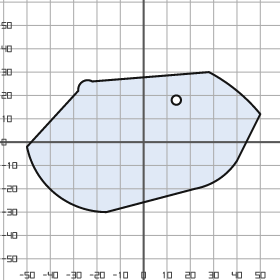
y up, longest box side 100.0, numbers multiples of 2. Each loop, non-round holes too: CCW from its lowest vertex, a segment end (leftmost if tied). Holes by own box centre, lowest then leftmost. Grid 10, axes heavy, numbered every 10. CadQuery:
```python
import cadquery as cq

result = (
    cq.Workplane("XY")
    .moveTo(-16.0, -30.0)
    .lineTo(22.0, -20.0)
    .threePointArc((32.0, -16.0), (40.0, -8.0))
    .lineTo(50.0, 12.0)
    .threePointArc((40.0, 22.0), (28.0, 30.0))
    .lineTo(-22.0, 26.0)
    .threePointArc((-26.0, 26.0), (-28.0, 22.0))
    .lineTo(-50.0, -2.0)
    .threePointArc((-38.0, -22.0), (-16.0, -30.0))
    .close()
    .moveTo(14.0, 18.0)
    .circle(2.0)
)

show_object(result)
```